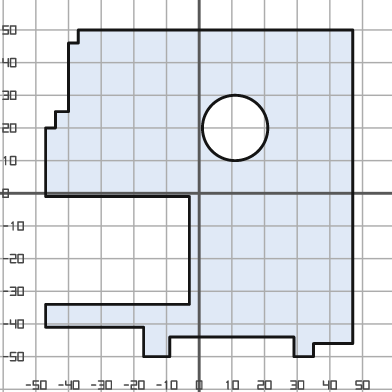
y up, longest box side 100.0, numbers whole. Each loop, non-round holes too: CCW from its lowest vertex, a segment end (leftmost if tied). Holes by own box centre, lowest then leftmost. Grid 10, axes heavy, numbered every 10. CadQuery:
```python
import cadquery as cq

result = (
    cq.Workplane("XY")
    .moveTo(-17.0, -50.0)
    .lineTo(-9.0, -50.0)
    .lineTo(-9.0, -44.0)
    .lineTo(29.0, -44.0)
    .lineTo(29.0, -50.0)
    .lineTo(35.0, -50.0)
    .lineTo(35.0, -46.0)
    .lineTo(47.0, -46.0)
    .lineTo(47.0, 50.0)
    .lineTo(-37.0, 50.0)
    .lineTo(-37.0, 46.0)
    .lineTo(-40.0, 46.0)
    .lineTo(-40.0, 25.0)
    .lineTo(-44.0, 25.0)
    .lineTo(-44.0, 20.0)
    .lineTo(-47.0, 20.0)
    .lineTo(-47.0, -1.0)
    .lineTo(-3.0, -1.0)
    .lineTo(-3.0, -34.0)
    .lineTo(-47.0, -34.0)
    .lineTo(-47.0, -41.0)
    .lineTo(-17.0, -41.0)
    .close()
    .moveTo(11.0, 20.0)
    .circle(10.0)
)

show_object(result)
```